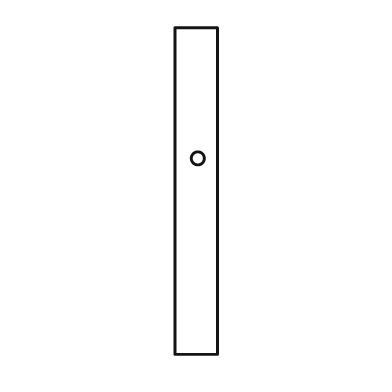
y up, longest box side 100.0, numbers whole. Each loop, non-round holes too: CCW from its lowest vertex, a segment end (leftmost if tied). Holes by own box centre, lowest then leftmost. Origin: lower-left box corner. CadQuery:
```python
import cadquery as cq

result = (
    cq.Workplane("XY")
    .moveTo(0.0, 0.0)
    .lineTo(13.0, 0.0)
    .lineTo(13.0, 100.0)
    .lineTo(0.0, 100.0)
    .close()
    .moveTo(7.0, 60.0)
    .circle(2.0)
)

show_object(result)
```